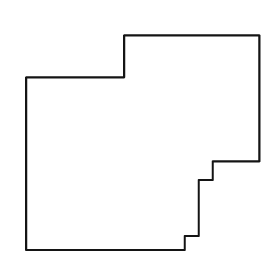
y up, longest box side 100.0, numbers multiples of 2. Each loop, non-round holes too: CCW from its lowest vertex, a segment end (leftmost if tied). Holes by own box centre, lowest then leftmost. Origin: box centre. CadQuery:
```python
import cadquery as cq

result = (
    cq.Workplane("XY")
    .moveTo(-50.0, -46.0)
    .lineTo(18.0, -46.0)
    .lineTo(18.0, -40.0)
    .lineTo(24.0, -40.0)
    .lineTo(24.0, -16.0)
    .lineTo(30.0, -16.0)
    .lineTo(30.0, -8.0)
    .lineTo(50.0, -8.0)
    .lineTo(50.0, 46.0)
    .lineTo(-8.0, 46.0)
    .lineTo(-8.0, 28.0)
    .lineTo(-50.0, 28.0)
    .close()
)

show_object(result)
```